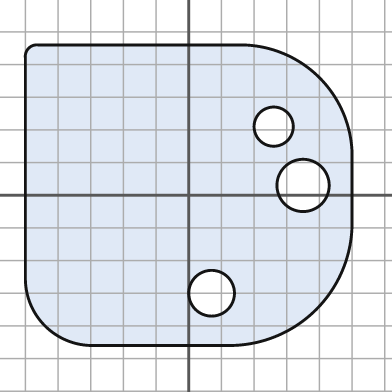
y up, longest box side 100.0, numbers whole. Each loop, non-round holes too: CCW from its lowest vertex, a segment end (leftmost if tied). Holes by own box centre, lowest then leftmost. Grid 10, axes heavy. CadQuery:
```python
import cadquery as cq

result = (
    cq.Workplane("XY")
    .moveTo(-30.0, -46.0)
    .lineTo(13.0, -46.0)
    .threePointArc((39.0, -35.0), (50.0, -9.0))
    .lineTo(50.0, 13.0)
    .threePointArc((40.0, 36.0), (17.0, 46.0))
    .lineTo(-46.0, 46.0)
    .threePointArc((-49.0, 45.0), (-50.0, 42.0))
    .lineTo(-50.0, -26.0)
    .threePointArc((-44.0, -40.0), (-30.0, -46.0))
    .close()
    .moveTo(7.0, -30.0)
    .circle(7.0)
    .moveTo(35.0, 3.0)
    .circle(8.0)
    .moveTo(26.0, 21.0)
    .circle(6.0)
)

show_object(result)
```